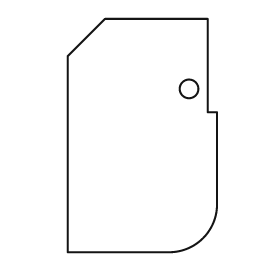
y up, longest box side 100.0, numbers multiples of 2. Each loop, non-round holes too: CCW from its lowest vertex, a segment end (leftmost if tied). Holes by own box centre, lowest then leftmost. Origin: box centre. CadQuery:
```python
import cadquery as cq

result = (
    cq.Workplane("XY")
    .moveTo(-32.0, -50.0)
    .lineTo(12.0, -50.0)
    .threePointArc((26.0, -44.0), (32.0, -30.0))
    .lineTo(32.0, 10.0)
    .lineTo(28.0, 10.0)
    .lineTo(28.0, 50.0)
    .lineTo(-16.0, 50.0)
    .lineTo(-32.0, 34.0)
    .close()
    .moveTo(20.0, 20.0)
    .circle(4.0)
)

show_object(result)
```